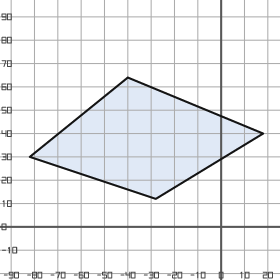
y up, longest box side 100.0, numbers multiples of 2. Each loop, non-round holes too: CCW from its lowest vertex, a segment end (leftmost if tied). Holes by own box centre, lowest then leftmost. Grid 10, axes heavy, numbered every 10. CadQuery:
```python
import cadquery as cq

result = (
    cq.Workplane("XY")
    .moveTo(-28.0, 12.0)
    .lineTo(18.0, 40.0)
    .lineTo(-40.0, 64.0)
    .lineTo(-82.0, 30.0)
    .close()
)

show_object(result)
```